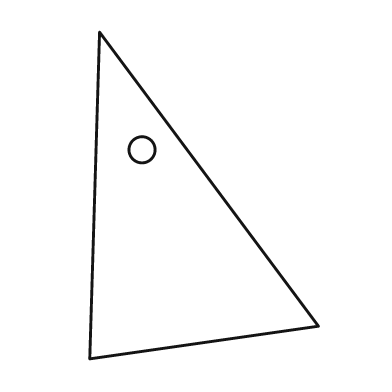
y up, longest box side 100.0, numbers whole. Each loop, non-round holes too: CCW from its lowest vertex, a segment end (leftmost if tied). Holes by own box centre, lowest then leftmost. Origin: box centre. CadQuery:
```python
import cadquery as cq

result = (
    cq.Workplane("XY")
    .moveTo(-35.0, -50.0)
    .lineTo(35.0, -40.0)
    .lineTo(-32.0, 50.0)
    .close()
    .moveTo(-19.0, 14.0)
    .circle(4.0)
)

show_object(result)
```